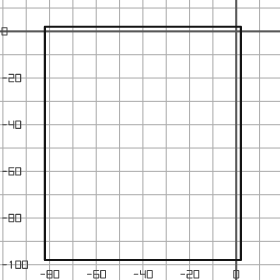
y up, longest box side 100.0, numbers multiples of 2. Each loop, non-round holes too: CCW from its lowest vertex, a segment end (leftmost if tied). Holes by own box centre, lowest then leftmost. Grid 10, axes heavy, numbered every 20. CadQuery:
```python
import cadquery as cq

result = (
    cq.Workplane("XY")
    .moveTo(-82.0, -98.0)
    .lineTo(2.0, -98.0)
    .lineTo(2.0, 2.0)
    .lineTo(-82.0, 2.0)
    .close()
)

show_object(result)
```